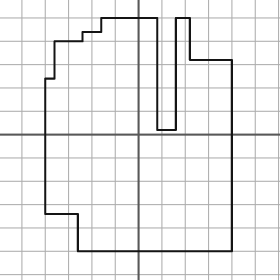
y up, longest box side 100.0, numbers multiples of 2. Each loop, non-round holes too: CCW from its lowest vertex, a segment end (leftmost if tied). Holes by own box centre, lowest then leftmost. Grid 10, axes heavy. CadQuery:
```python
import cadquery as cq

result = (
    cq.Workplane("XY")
    .moveTo(-26.0, -50.0)
    .lineTo(40.0, -50.0)
    .lineTo(40.0, 32.0)
    .lineTo(22.0, 32.0)
    .lineTo(22.0, 50.0)
    .lineTo(16.0, 50.0)
    .lineTo(16.0, 2.0)
    .lineTo(8.0, 2.0)
    .lineTo(8.0, 50.0)
    .lineTo(-16.0, 50.0)
    .lineTo(-16.0, 44.0)
    .lineTo(-24.0, 44.0)
    .lineTo(-24.0, 40.0)
    .lineTo(-36.0, 40.0)
    .lineTo(-36.0, 24.0)
    .lineTo(-40.0, 24.0)
    .lineTo(-40.0, -34.0)
    .lineTo(-26.0, -34.0)
    .close()
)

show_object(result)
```